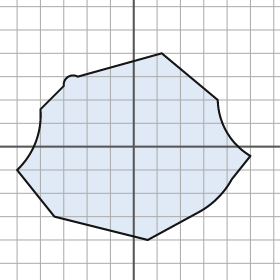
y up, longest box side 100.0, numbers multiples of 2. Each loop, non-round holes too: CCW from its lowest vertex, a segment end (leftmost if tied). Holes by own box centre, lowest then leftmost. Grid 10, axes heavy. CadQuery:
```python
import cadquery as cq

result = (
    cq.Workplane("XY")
    .moveTo(6.0, -40.0)
    .lineTo(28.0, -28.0)
    .threePointArc((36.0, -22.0), (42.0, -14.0))
    .lineTo(50.0, -4.0)
    .threePointArc((40.0, 6.0), (36.0, 20.0))
    .lineTo(12.0, 40.0)
    .lineTo(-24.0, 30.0)
    .threePointArc((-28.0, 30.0), (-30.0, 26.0))
    .lineTo(-40.0, 16.0)
    .threePointArc((-42.0, 2.0), (-50.0, -10.0))
    .lineTo(-34.0, -30.0)
    .close()
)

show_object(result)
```